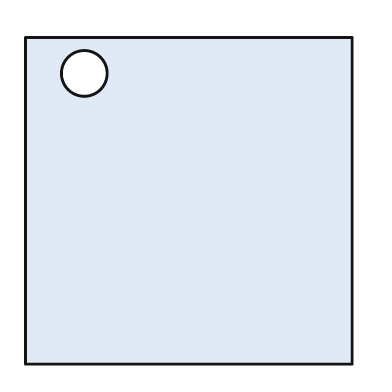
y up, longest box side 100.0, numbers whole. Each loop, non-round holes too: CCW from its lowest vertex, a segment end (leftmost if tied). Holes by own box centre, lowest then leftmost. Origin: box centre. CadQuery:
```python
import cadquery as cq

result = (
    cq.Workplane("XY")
    .moveTo(-50.0, -50.0)
    .lineTo(50.0, -50.0)
    .lineTo(50.0, 50.0)
    .lineTo(-50.0, 50.0)
    .close()
    .moveTo(-32.0, 39.0)
    .circle(7.0)
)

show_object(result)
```